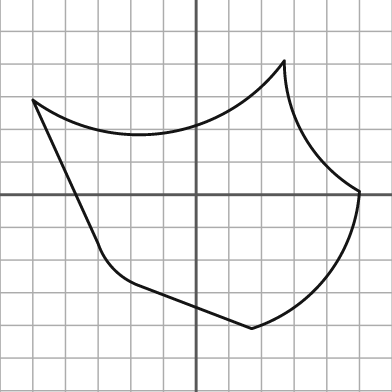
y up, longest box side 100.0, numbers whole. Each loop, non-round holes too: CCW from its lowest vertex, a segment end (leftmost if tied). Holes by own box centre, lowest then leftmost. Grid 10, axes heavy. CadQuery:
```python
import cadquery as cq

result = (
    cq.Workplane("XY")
    .moveTo(17.0, -41.0)
    .threePointArc((40.0, -25.0), (50.0, 1.0))
    .threePointArc((33.0, 18.0), (27.0, 41.0))
    .threePointArc((-9.0, 19.0), (-50.0, 29.0))
    .lineTo(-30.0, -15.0)
    .threePointArc((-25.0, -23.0), (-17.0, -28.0))
    .close()
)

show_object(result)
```